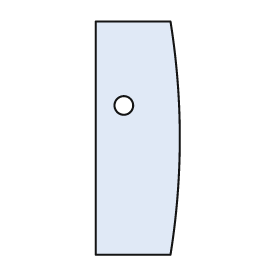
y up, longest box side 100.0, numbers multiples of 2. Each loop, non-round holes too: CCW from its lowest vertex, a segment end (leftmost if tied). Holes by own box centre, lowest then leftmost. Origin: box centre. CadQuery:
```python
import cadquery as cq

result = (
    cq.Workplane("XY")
    .moveTo(-18.0, -50.0)
    .lineTo(14.0, -50.0)
    .threePointArc((18.0, 0.0), (14.0, 50.0))
    .lineTo(-18.0, 50.0)
    .close()
    .moveTo(-6.0, 14.0)
    .circle(4.0)
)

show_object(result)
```